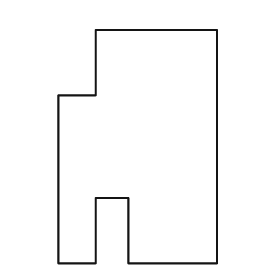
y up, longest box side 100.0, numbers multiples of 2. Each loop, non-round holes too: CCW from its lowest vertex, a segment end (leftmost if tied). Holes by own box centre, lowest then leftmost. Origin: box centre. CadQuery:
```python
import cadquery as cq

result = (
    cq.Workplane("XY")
    .moveTo(-34.0, -50.0)
    .lineTo(-18.0, -50.0)
    .lineTo(-18.0, -22.0)
    .lineTo(-4.0, -22.0)
    .lineTo(-4.0, -50.0)
    .lineTo(34.0, -50.0)
    .lineTo(34.0, 50.0)
    .lineTo(-18.0, 50.0)
    .lineTo(-18.0, 22.0)
    .lineTo(-34.0, 22.0)
    .close()
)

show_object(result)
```